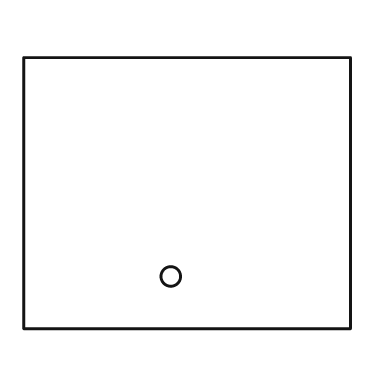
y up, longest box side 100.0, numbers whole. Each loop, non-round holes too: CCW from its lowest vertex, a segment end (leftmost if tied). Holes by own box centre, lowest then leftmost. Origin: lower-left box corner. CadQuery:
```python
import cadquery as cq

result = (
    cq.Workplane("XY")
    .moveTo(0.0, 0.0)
    .lineTo(100.0, 0.0)
    .lineTo(100.0, 83.0)
    .lineTo(0.0, 83.0)
    .close()
    .moveTo(45.0, 16.0)
    .circle(3.0)
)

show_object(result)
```